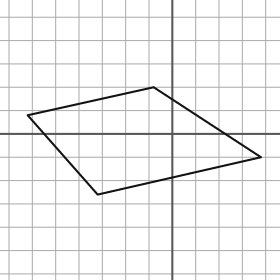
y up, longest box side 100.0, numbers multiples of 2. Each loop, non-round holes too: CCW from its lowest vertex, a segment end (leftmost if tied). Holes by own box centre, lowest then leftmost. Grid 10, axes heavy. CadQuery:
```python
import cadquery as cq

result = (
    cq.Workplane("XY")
    .moveTo(-32.0, -26.0)
    .lineTo(38.0, -10.0)
    .lineTo(-8.0, 20.0)
    .lineTo(-62.0, 8.0)
    .close()
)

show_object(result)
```